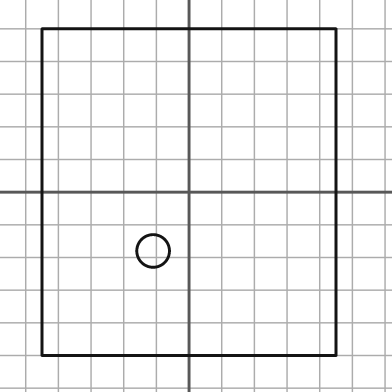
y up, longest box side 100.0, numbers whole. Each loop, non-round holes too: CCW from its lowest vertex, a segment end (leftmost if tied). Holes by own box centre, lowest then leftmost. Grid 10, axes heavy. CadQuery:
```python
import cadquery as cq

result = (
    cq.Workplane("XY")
    .moveTo(-45.0, -50.0)
    .lineTo(45.0, -50.0)
    .lineTo(45.0, 50.0)
    .lineTo(-45.0, 50.0)
    .close()
    .moveTo(-11.0, -18.0)
    .circle(5.0)
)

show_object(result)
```